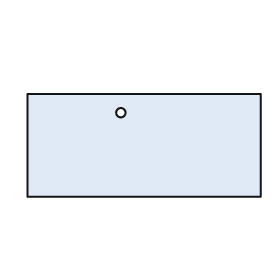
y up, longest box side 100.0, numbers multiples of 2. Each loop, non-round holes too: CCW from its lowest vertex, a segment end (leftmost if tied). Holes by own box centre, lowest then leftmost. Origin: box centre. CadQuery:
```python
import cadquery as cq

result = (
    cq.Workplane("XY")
    .moveTo(-50.0, -22.0)
    .lineTo(50.0, -22.0)
    .lineTo(50.0, 22.0)
    .lineTo(-50.0, 22.0)
    .close()
    .moveTo(-10.0, 14.0)
    .circle(2.0)
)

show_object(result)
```